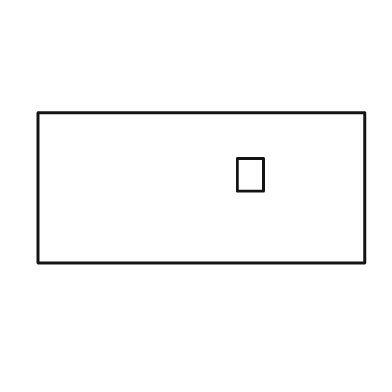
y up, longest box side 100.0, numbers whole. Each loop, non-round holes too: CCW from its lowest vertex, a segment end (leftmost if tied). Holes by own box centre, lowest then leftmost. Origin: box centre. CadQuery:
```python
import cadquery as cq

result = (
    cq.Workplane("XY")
    .moveTo(-50.0, -23.0)
    .lineTo(50.0, -23.0)
    .lineTo(50.0, 23.0)
    .lineTo(-50.0, 23.0)
    .close()
    .moveTo(11.0, -1.0)
    .lineTo(19.0, -1.0)
    .lineTo(19.0, 9.0)
    .lineTo(11.0, 9.0)
    .close()
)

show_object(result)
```